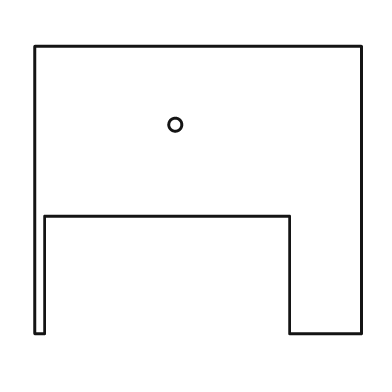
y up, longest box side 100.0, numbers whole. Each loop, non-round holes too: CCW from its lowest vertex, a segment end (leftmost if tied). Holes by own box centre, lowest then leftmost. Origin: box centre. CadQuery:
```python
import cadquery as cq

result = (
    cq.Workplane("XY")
    .moveTo(-50.0, -44.0)
    .lineTo(-47.0, -44.0)
    .lineTo(-47.0, -8.0)
    .lineTo(28.0, -8.0)
    .lineTo(28.0, -44.0)
    .lineTo(50.0, -44.0)
    .lineTo(50.0, 44.0)
    .lineTo(-50.0, 44.0)
    .close()
    .moveTo(-7.0, 20.0)
    .circle(2.0)
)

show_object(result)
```